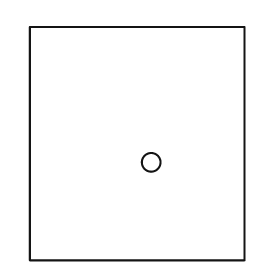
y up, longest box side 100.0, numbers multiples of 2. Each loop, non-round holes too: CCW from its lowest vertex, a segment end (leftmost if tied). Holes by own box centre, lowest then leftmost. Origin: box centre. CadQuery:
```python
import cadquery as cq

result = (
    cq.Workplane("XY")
    .moveTo(-46.0, -50.0)
    .lineTo(46.0, -50.0)
    .lineTo(46.0, 50.0)
    .lineTo(-46.0, 50.0)
    .close()
    .moveTo(6.0, -8.0)
    .circle(4.0)
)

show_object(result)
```